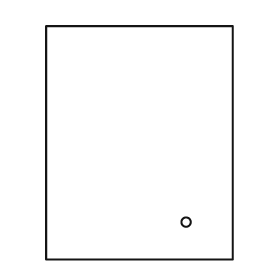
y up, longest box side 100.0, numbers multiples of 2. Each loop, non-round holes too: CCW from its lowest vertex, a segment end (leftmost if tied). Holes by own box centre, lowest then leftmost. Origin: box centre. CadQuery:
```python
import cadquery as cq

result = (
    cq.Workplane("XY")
    .moveTo(-40.0, -50.0)
    .lineTo(40.0, -50.0)
    .lineTo(40.0, 50.0)
    .lineTo(-40.0, 50.0)
    .close()
    .moveTo(20.0, -34.0)
    .circle(2.0)
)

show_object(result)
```